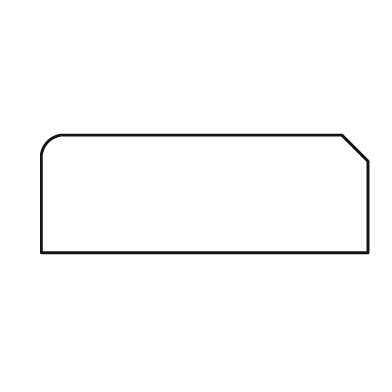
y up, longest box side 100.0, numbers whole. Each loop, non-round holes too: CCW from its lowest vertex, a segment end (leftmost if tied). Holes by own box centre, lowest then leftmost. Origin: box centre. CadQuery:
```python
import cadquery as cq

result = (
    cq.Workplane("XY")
    .moveTo(-50.0, -18.0)
    .lineTo(50.0, -18.0)
    .lineTo(50.0, 10.0)
    .lineTo(42.0, 18.0)
    .lineTo(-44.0, 18.0)
    .threePointArc((-48.0, 16.0), (-50.0, 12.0))
    .close()
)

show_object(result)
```